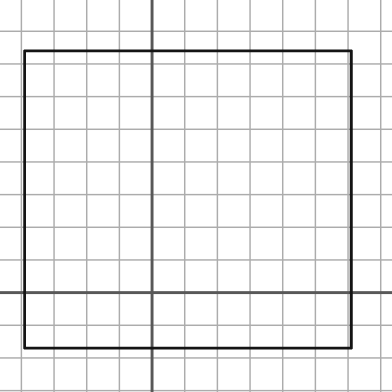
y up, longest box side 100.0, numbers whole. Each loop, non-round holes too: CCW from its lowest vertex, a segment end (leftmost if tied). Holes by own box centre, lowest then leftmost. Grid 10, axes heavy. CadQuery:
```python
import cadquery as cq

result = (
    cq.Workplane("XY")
    .moveTo(-39.0, -17.0)
    .lineTo(61.0, -17.0)
    .lineTo(61.0, 74.0)
    .lineTo(-39.0, 74.0)
    .close()
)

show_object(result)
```